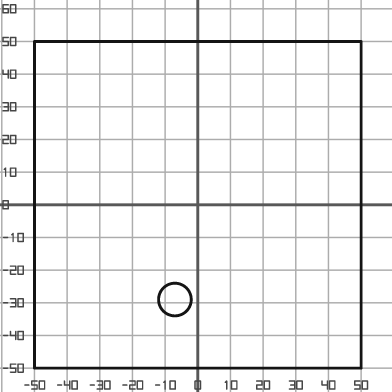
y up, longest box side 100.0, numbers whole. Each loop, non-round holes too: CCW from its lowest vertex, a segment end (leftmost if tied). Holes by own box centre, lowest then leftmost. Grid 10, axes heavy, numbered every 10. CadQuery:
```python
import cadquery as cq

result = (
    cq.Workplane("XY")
    .moveTo(-50.0, -50.0)
    .lineTo(50.0, -50.0)
    .lineTo(50.0, 50.0)
    .lineTo(-50.0, 50.0)
    .close()
    .moveTo(-7.0, -29.0)
    .circle(5.0)
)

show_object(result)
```